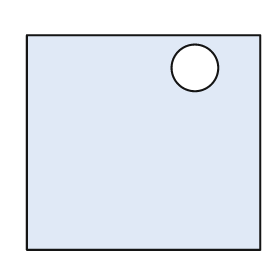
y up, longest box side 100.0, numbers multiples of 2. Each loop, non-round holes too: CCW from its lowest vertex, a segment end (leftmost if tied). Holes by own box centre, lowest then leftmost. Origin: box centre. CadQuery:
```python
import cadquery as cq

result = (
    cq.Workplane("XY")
    .moveTo(-50.0, -46.0)
    .lineTo(50.0, -46.0)
    .lineTo(50.0, 46.0)
    .lineTo(-50.0, 46.0)
    .close()
    .moveTo(22.0, 32.0)
    .circle(10.0)
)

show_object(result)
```